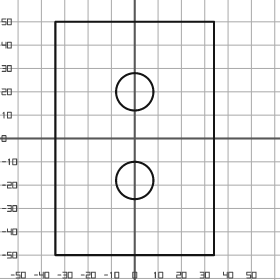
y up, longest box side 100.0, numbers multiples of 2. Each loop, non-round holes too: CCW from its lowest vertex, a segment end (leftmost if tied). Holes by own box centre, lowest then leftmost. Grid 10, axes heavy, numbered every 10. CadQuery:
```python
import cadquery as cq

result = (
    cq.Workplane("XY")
    .moveTo(-34.0, -50.0)
    .lineTo(34.0, -50.0)
    .lineTo(34.0, 50.0)
    .lineTo(-34.0, 50.0)
    .close()
    .moveTo(0.0, -18.0)
    .circle(8.0)
    .moveTo(0.0, 20.0)
    .circle(8.0)
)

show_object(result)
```